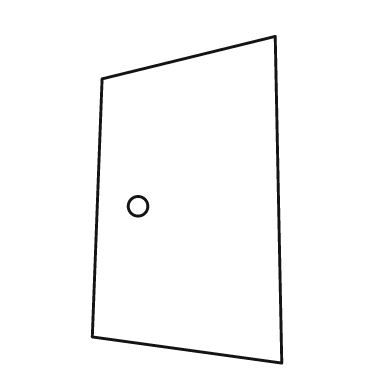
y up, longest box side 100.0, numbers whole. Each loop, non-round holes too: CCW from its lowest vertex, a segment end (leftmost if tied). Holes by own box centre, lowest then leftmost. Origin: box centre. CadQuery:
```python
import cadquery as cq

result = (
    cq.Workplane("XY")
    .moveTo(29.0, -50.0)
    .lineTo(27.0, 50.0)
    .lineTo(-26.0, 37.0)
    .lineTo(-29.0, -42.0)
    .close()
    .moveTo(-15.0, -2.0)
    .circle(3.0)
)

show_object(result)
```